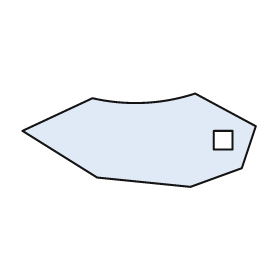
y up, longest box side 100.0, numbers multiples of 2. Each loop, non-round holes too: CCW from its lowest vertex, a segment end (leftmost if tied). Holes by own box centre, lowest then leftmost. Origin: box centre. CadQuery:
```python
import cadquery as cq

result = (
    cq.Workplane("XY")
    .moveTo(22.0, -20.0)
    .lineTo(44.0, -12.0)
    .lineTo(50.0, 6.0)
    .lineTo(24.0, 20.0)
    .threePointArc((2.0, 16.0), (-20.0, 18.0))
    .lineTo(-50.0, 4.0)
    .lineTo(-18.0, -16.0)
    .close()
    .moveTo(32.0, -4.0)
    .lineTo(40.0, -4.0)
    .lineTo(40.0, 4.0)
    .lineTo(32.0, 4.0)
    .close()
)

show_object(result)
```